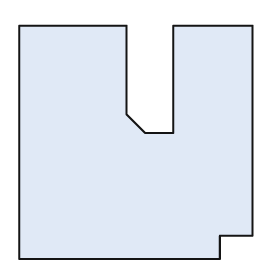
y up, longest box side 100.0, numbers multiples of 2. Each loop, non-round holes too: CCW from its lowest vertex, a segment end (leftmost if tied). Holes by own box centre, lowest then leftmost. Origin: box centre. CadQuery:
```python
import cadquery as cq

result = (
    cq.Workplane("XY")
    .moveTo(-50.0, -50.0)
    .lineTo(36.0, -50.0)
    .lineTo(36.0, -40.0)
    .lineTo(50.0, -40.0)
    .lineTo(50.0, 50.0)
    .lineTo(16.0, 50.0)
    .lineTo(16.0, 4.0)
    .lineTo(4.0, 4.0)
    .lineTo(-4.0, 12.0)
    .lineTo(-4.0, 50.0)
    .lineTo(-50.0, 50.0)
    .close()
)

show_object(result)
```